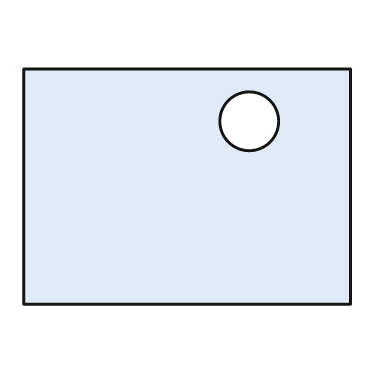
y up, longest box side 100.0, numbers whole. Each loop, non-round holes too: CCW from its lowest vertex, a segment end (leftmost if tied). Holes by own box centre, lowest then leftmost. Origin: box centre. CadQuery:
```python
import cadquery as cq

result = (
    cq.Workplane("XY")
    .moveTo(-50.0, -36.0)
    .lineTo(50.0, -36.0)
    .lineTo(50.0, 36.0)
    .lineTo(-50.0, 36.0)
    .close()
    .moveTo(19.0, 20.0)
    .circle(9.0)
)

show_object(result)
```